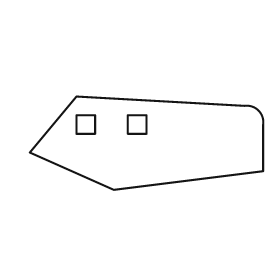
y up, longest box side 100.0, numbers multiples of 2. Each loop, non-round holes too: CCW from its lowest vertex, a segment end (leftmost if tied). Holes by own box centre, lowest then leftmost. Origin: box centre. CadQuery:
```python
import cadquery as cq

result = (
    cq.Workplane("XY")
    .moveTo(-14.0, -20.0)
    .lineTo(50.0, -12.0)
    .lineTo(50.0, 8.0)
    .threePointArc((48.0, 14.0), (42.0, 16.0))
    .lineTo(-30.0, 20.0)
    .lineTo(-50.0, -4.0)
    .close()
    .moveTo(-30.0, 4.0)
    .lineTo(-22.0, 4.0)
    .lineTo(-22.0, 12.0)
    .lineTo(-30.0, 12.0)
    .close()
    .moveTo(-8.0, 4.0)
    .lineTo(0.0, 4.0)
    .lineTo(0.0, 12.0)
    .lineTo(-8.0, 12.0)
    .close()
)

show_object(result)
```